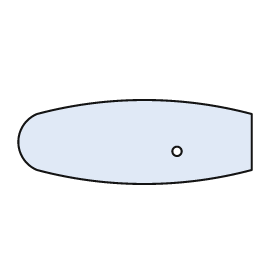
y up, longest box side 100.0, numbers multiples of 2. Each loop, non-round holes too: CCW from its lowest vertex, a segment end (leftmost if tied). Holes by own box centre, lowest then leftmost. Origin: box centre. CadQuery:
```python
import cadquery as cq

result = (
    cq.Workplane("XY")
    .moveTo(-42.0, -12.0)
    .threePointArc((4.0, -18.0), (50.0, -12.0))
    .lineTo(50.0, 12.0)
    .threePointArc((4.0, 18.0), (-42.0, 12.0))
    .threePointArc((-50.0, 0.0), (-42.0, -12.0))
    .close()
    .moveTo(18.0, -4.0)
    .circle(2.0)
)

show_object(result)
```